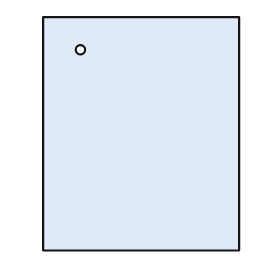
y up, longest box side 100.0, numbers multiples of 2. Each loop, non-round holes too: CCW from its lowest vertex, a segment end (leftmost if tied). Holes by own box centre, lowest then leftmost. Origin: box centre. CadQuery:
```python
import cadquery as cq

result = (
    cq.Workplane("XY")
    .moveTo(-42.0, -50.0)
    .lineTo(42.0, -50.0)
    .lineTo(42.0, 50.0)
    .lineTo(-42.0, 50.0)
    .close()
    .moveTo(-26.0, 36.0)
    .circle(2.0)
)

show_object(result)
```